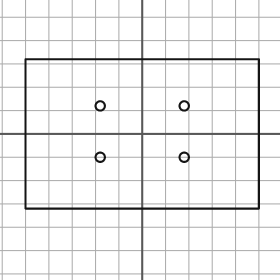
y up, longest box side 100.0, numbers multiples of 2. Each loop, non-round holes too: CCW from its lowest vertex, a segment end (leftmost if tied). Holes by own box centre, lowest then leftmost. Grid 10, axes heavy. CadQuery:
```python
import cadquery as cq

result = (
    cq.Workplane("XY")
    .moveTo(-50.0, -32.0)
    .lineTo(50.0, -32.0)
    .lineTo(50.0, 32.0)
    .lineTo(-50.0, 32.0)
    .close()
    .moveTo(-18.0, -10.0)
    .circle(2.0)
    .moveTo(18.0, -10.0)
    .circle(2.0)
    .moveTo(-18.0, 12.0)
    .circle(2.0)
    .moveTo(18.0, 12.0)
    .circle(2.0)
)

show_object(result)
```